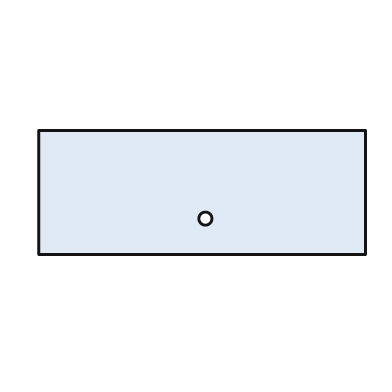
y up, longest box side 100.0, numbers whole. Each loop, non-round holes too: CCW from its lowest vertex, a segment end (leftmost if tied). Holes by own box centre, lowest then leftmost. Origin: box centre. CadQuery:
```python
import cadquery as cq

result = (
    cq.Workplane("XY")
    .moveTo(-50.0, -19.0)
    .lineTo(50.0, -19.0)
    .lineTo(50.0, 19.0)
    .lineTo(-50.0, 19.0)
    .close()
    .moveTo(1.0, -8.0)
    .circle(2.0)
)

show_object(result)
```